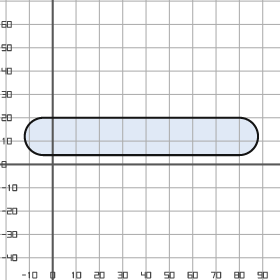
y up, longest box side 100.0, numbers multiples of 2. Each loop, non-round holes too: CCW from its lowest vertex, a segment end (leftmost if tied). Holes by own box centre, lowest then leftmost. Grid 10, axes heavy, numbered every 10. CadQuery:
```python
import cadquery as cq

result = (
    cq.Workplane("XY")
    .moveTo(-4.0, 4.0)
    .lineTo(80.0, 4.0)
    .threePointArc((88.0, 12.0), (80.0, 20.0))
    .lineTo(-4.0, 20.0)
    .threePointArc((-12.0, 12.0), (-4.0, 4.0))
    .close()
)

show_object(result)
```